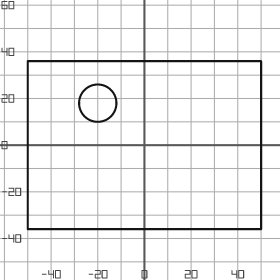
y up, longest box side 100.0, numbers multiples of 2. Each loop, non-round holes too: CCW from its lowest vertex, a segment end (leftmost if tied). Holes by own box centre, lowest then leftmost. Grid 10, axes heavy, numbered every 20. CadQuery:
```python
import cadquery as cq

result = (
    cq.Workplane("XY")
    .moveTo(-50.0, -36.0)
    .lineTo(50.0, -36.0)
    .lineTo(50.0, 36.0)
    .lineTo(-50.0, 36.0)
    .close()
    .moveTo(-20.0, 18.0)
    .circle(8.0)
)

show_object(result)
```